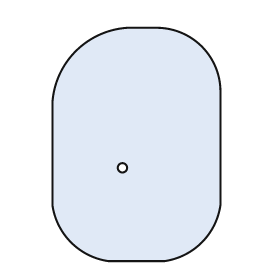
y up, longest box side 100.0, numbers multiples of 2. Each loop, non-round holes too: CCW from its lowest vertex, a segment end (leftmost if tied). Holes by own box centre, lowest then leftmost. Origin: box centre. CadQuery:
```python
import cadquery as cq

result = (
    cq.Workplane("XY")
    .moveTo(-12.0, -50.0)
    .lineTo(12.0, -50.0)
    .threePointArc((28.0, -42.0), (36.0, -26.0))
    .lineTo(36.0, 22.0)
    .threePointArc((28.0, 42.0), (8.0, 50.0))
    .lineTo(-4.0, 50.0)
    .threePointArc((-26.0, 40.0), (-36.0, 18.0))
    .lineTo(-36.0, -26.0)
    .threePointArc((-28.0, -42.0), (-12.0, -50.0))
    .close()
    .moveTo(-6.0, -10.0)
    .circle(2.0)
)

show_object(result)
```